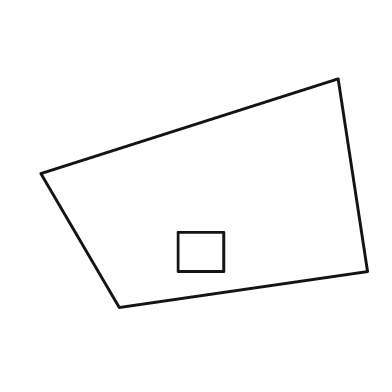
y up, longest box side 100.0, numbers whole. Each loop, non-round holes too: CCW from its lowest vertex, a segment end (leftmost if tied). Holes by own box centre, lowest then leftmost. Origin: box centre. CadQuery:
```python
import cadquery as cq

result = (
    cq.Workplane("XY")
    .moveTo(-26.0, -35.0)
    .lineTo(50.0, -24.0)
    .lineTo(41.0, 35.0)
    .lineTo(-50.0, 6.0)
    .close()
    .moveTo(-8.0, -24.0)
    .lineTo(6.0, -24.0)
    .lineTo(6.0, -12.0)
    .lineTo(-8.0, -12.0)
    .close()
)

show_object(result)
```